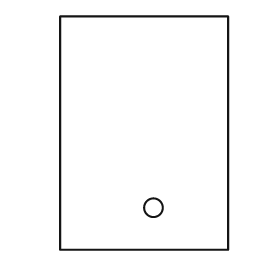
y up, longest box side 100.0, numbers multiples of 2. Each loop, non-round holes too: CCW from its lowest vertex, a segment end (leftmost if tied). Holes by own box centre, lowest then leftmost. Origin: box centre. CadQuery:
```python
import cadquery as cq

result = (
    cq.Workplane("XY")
    .moveTo(-36.0, -50.0)
    .lineTo(36.0, -50.0)
    .lineTo(36.0, 50.0)
    .lineTo(-36.0, 50.0)
    .close()
    .moveTo(4.0, -32.0)
    .circle(4.0)
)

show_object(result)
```